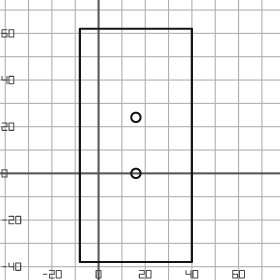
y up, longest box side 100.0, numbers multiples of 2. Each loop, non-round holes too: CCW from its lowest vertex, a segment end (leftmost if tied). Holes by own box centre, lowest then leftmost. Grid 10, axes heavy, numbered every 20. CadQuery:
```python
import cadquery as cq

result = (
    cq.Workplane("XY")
    .moveTo(-8.0, -38.0)
    .lineTo(40.0, -38.0)
    .lineTo(40.0, 62.0)
    .lineTo(-8.0, 62.0)
    .close()
    .moveTo(16.0, 0.0)
    .circle(2.0)
    .moveTo(16.0, 24.0)
    .circle(2.0)
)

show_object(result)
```